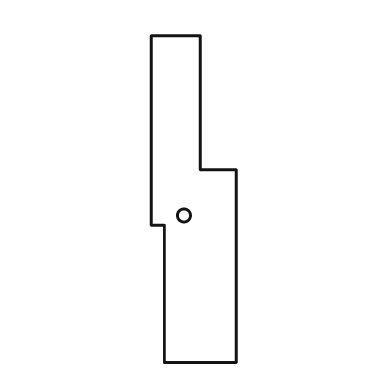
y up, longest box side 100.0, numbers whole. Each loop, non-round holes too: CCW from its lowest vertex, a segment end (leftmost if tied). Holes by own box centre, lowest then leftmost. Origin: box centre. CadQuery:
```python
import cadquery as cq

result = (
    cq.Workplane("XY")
    .moveTo(-9.0, -50.0)
    .lineTo(13.0, -50.0)
    .lineTo(13.0, 9.0)
    .lineTo(2.0, 9.0)
    .lineTo(2.0, 50.0)
    .lineTo(-13.0, 50.0)
    .lineTo(-13.0, -8.0)
    .lineTo(-9.0, -8.0)
    .close()
    .moveTo(-3.0, -5.0)
    .circle(2.0)
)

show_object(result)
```